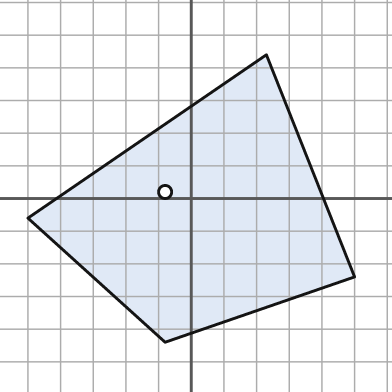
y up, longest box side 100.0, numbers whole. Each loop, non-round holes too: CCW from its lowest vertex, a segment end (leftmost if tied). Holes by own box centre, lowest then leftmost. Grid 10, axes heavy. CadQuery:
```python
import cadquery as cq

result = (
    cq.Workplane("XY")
    .moveTo(-8.0, -44.0)
    .lineTo(50.0, -24.0)
    .lineTo(23.0, 44.0)
    .lineTo(-50.0, -6.0)
    .close()
    .moveTo(-8.0, 2.0)
    .circle(2.0)
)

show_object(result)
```